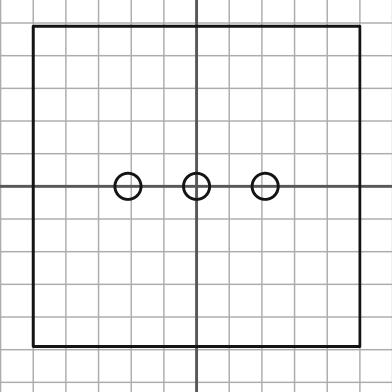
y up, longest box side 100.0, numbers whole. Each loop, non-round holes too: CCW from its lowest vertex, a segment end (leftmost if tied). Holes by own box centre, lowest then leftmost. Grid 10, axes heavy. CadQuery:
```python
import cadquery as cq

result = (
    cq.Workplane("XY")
    .moveTo(-50.0, -49.0)
    .lineTo(50.0, -49.0)
    .lineTo(50.0, 49.0)
    .lineTo(-50.0, 49.0)
    .close()
    .moveTo(-21.0, 0.0)
    .circle(4.0)
    .moveTo(0.0, 0.0)
    .circle(4.0)
    .moveTo(21.0, 0.0)
    .circle(4.0)
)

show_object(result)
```